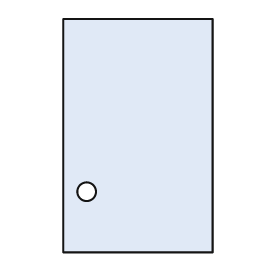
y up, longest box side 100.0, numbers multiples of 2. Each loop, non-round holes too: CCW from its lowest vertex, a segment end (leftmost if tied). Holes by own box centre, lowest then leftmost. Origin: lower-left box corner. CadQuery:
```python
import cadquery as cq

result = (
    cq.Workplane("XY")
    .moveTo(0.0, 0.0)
    .lineTo(64.0, 0.0)
    .lineTo(64.0, 100.0)
    .lineTo(0.0, 100.0)
    .close()
    .moveTo(10.0, 26.0)
    .circle(4.0)
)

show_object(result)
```